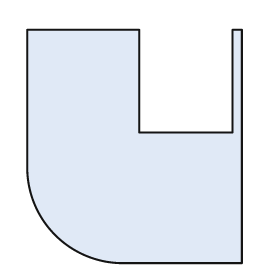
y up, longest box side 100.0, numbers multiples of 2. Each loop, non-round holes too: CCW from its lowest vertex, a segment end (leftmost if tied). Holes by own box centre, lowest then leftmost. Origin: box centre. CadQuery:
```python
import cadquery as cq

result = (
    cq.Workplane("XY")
    .moveTo(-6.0, -50.0)
    .lineTo(46.0, -50.0)
    .lineTo(46.0, 50.0)
    .lineTo(42.0, 50.0)
    .lineTo(42.0, 6.0)
    .lineTo(2.0, 6.0)
    .lineTo(2.0, 50.0)
    .lineTo(-46.0, 50.0)
    .lineTo(-46.0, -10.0)
    .threePointArc((-34.0, -38.0), (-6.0, -50.0))
    .close()
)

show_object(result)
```